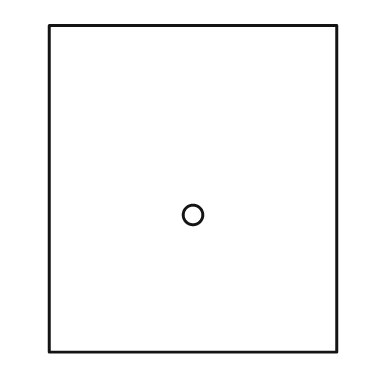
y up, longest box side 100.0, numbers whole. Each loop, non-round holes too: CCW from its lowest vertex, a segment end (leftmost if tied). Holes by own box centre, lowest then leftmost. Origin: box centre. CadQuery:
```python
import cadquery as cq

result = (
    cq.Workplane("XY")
    .moveTo(-44.0, -50.0)
    .lineTo(44.0, -50.0)
    .lineTo(44.0, 50.0)
    .lineTo(-44.0, 50.0)
    .close()
    .moveTo(0.0, -8.0)
    .circle(3.0)
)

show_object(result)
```